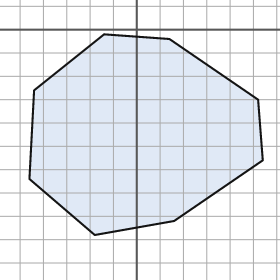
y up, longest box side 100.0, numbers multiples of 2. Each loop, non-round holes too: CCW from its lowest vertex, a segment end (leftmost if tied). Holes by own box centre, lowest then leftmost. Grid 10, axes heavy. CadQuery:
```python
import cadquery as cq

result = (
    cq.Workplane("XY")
    .moveTo(-18.0, -88.0)
    .lineTo(16.0, -82.0)
    .lineTo(54.0, -56.0)
    .lineTo(52.0, -30.0)
    .lineTo(14.0, -4.0)
    .lineTo(-14.0, -2.0)
    .lineTo(-44.0, -26.0)
    .lineTo(-46.0, -64.0)
    .close()
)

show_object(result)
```